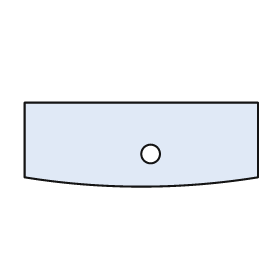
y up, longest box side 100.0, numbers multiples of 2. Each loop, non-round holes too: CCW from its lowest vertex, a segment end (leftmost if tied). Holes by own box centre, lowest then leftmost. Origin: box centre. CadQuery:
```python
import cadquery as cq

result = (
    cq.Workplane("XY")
    .moveTo(-50.0, -14.0)
    .threePointArc((0.0, -18.0), (50.0, -14.0))
    .lineTo(50.0, 18.0)
    .lineTo(-50.0, 18.0)
    .close()
    .moveTo(4.0, -4.0)
    .circle(4.0)
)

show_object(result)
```